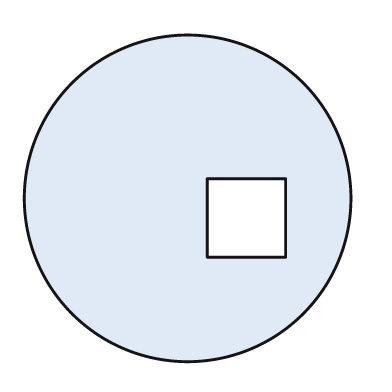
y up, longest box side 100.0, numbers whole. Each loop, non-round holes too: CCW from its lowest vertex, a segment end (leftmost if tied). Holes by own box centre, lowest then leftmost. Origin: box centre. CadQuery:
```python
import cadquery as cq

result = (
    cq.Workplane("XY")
    .moveTo(0.0, 0.0)
    .circle(50.0)
    .moveTo(6.0, -18.0)
    .lineTo(30.0, -18.0)
    .lineTo(30.0, 6.0)
    .lineTo(6.0, 6.0)
    .close()
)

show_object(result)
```